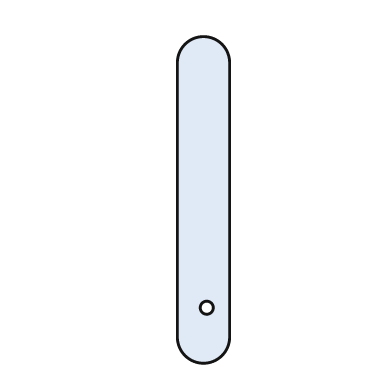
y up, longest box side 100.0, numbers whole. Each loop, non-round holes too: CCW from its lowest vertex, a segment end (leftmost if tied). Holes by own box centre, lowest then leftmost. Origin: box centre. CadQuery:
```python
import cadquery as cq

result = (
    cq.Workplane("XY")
    .moveTo(-8.0, -42.0)
    .threePointArc((0.0, -50.0), (8.0, -42.0))
    .lineTo(8.0, 42.0)
    .threePointArc((0.0, 50.0), (-8.0, 42.0))
    .close()
    .moveTo(1.0, -33.0)
    .circle(2.0)
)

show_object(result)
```